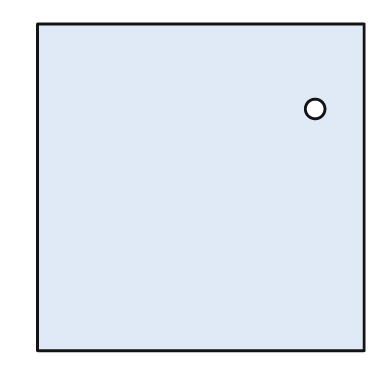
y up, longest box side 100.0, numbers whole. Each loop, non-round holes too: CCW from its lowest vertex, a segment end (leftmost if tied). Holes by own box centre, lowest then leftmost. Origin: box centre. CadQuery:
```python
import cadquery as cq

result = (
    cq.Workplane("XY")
    .moveTo(-50.0, -50.0)
    .lineTo(50.0, -50.0)
    .lineTo(50.0, 50.0)
    .lineTo(-50.0, 50.0)
    .close()
    .moveTo(35.0, 24.0)
    .circle(3.0)
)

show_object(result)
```